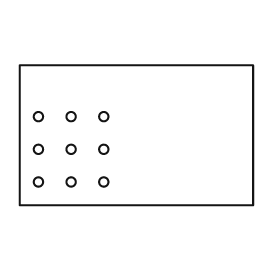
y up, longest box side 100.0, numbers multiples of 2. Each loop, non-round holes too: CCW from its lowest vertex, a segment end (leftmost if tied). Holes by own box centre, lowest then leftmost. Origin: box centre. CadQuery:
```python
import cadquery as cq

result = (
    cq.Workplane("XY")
    .moveTo(-50.0, -30.0)
    .lineTo(50.0, -30.0)
    .lineTo(50.0, 30.0)
    .lineTo(-50.0, 30.0)
    .close()
    .moveTo(-42.0, -20.0)
    .circle(2.0)
    .moveTo(-28.0, -20.0)
    .circle(2.0)
    .moveTo(-14.0, -20.0)
    .circle(2.0)
    .moveTo(-42.0, -6.0)
    .circle(2.0)
    .moveTo(-28.0, -6.0)
    .circle(2.0)
    .moveTo(-14.0, -6.0)
    .circle(2.0)
    .moveTo(-42.0, 8.0)
    .circle(2.0)
    .moveTo(-28.0, 8.0)
    .circle(2.0)
    .moveTo(-14.0, 8.0)
    .circle(2.0)
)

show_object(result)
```